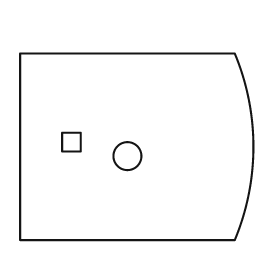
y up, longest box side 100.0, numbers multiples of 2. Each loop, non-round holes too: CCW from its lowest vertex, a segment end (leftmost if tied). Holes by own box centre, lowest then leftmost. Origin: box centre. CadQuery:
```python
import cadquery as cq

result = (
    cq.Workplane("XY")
    .moveTo(-50.0, -40.0)
    .lineTo(42.0, -40.0)
    .threePointArc((50.0, 0.0), (42.0, 40.0))
    .lineTo(-50.0, 40.0)
    .close()
    .moveTo(-4.0, -4.0)
    .circle(6.0)
    .moveTo(-32.0, -2.0)
    .lineTo(-24.0, -2.0)
    .lineTo(-24.0, 6.0)
    .lineTo(-32.0, 6.0)
    .close()
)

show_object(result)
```